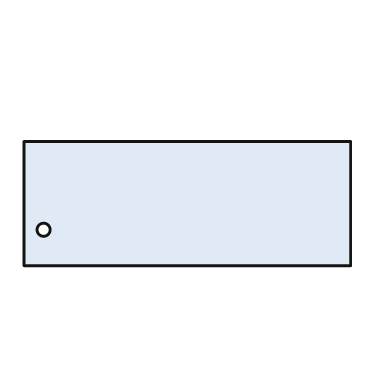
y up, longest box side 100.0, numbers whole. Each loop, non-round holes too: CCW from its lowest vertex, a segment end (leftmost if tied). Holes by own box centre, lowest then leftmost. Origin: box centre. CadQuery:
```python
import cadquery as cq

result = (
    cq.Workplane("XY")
    .moveTo(-50.0, -19.0)
    .lineTo(50.0, -19.0)
    .lineTo(50.0, 19.0)
    .lineTo(-50.0, 19.0)
    .close()
    .moveTo(-44.0, -8.0)
    .circle(2.0)
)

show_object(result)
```